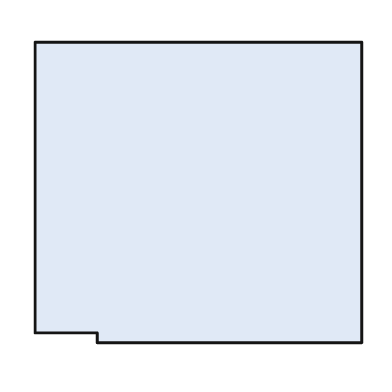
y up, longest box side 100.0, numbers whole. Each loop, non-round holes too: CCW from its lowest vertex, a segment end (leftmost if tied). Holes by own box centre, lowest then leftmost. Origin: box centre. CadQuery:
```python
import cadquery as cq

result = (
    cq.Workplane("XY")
    .moveTo(-31.0, -46.0)
    .lineTo(50.0, -46.0)
    .lineTo(50.0, 46.0)
    .lineTo(-50.0, 46.0)
    .lineTo(-50.0, -43.0)
    .lineTo(-31.0, -43.0)
    .close()
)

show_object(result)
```